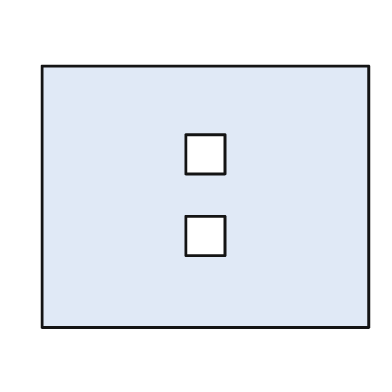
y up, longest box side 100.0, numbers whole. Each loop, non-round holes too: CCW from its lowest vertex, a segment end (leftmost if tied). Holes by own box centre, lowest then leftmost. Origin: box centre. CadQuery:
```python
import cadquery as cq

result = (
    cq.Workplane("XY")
    .moveTo(-50.0, -40.0)
    .lineTo(50.0, -40.0)
    .lineTo(50.0, 40.0)
    .lineTo(-50.0, 40.0)
    .close()
    .moveTo(-6.0, -18.0)
    .lineTo(6.0, -18.0)
    .lineTo(6.0, -6.0)
    .lineTo(-6.0, -6.0)
    .close()
    .moveTo(-6.0, 7.0)
    .lineTo(6.0, 7.0)
    .lineTo(6.0, 19.0)
    .lineTo(-6.0, 19.0)
    .close()
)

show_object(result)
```